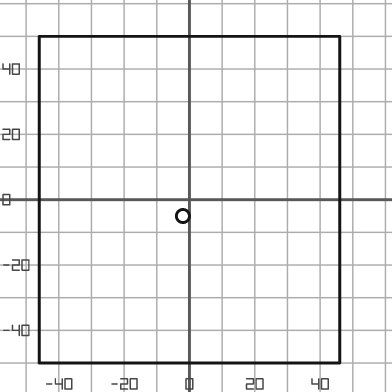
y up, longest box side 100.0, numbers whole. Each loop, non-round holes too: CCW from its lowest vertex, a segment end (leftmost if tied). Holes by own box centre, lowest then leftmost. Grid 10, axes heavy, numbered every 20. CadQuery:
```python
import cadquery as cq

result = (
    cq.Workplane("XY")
    .moveTo(-46.0, -50.0)
    .lineTo(46.0, -50.0)
    .lineTo(46.0, 50.0)
    .lineTo(-46.0, 50.0)
    .close()
    .moveTo(-2.0, -5.0)
    .circle(2.0)
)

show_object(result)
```